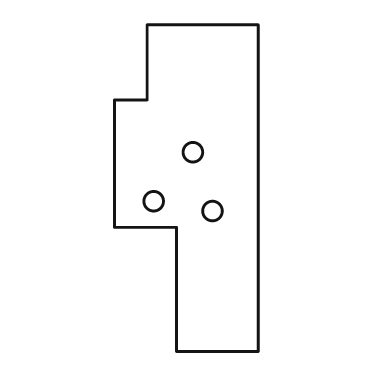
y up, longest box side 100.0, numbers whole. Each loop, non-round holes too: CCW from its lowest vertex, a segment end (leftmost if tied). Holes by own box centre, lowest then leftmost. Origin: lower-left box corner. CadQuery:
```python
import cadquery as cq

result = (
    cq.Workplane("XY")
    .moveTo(19.0, 0.0)
    .lineTo(44.0, 0.0)
    .lineTo(44.0, 100.0)
    .lineTo(10.0, 100.0)
    .lineTo(10.0, 77.0)
    .lineTo(0.0, 77.0)
    .lineTo(0.0, 38.0)
    .lineTo(19.0, 38.0)
    .close()
    .moveTo(30.0, 43.0)
    .circle(3.0)
    .moveTo(12.0, 46.0)
    .circle(3.0)
    .moveTo(24.0, 61.0)
    .circle(3.0)
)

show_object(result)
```